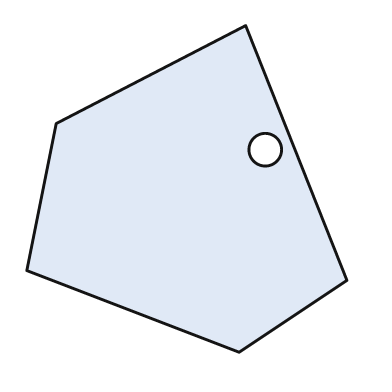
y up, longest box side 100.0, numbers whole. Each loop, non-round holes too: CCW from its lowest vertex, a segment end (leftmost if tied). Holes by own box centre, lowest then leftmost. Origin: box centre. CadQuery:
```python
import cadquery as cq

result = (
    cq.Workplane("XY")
    .moveTo(16.0, -50.0)
    .lineTo(49.0, -28.0)
    .lineTo(18.0, 50.0)
    .lineTo(-40.0, 20.0)
    .lineTo(-49.0, -25.0)
    .close()
    .moveTo(24.0, 12.0)
    .circle(5.0)
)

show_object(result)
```